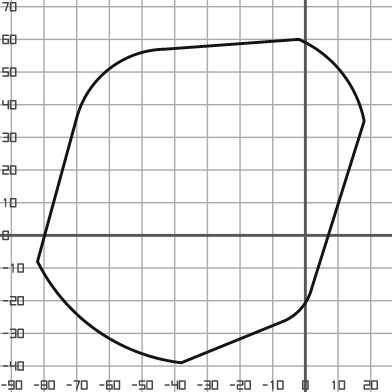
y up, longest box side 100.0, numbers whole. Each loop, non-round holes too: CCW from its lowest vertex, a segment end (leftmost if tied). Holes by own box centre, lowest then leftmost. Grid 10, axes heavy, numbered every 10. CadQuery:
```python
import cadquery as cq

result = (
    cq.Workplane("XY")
    .moveTo(-38.0, -39.0)
    .lineTo(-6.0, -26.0)
    .threePointArc((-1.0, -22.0), (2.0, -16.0))
    .lineTo(18.0, 35.0)
    .threePointArc((11.0, 50.0), (-2.0, 60.0))
    .lineTo(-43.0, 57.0)
    .threePointArc((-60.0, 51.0), (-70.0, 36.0))
    .lineTo(-82.0, -8.0)
    .threePointArc((-64.0, -29.0), (-38.0, -39.0))
    .close()
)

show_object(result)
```